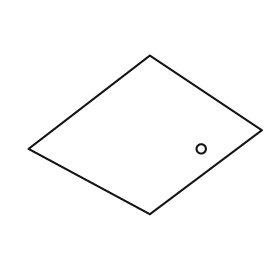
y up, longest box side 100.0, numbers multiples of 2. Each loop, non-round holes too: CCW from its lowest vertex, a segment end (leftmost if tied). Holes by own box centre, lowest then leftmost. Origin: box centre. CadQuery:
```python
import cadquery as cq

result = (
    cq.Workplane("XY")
    .moveTo(2.0, -34.0)
    .lineTo(50.0, 2.0)
    .lineTo(2.0, 34.0)
    .lineTo(-50.0, -6.0)
    .close()
    .moveTo(24.0, -6.0)
    .circle(2.0)
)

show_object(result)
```